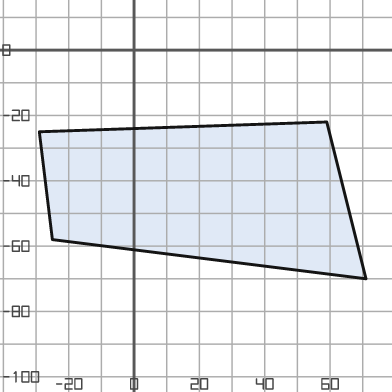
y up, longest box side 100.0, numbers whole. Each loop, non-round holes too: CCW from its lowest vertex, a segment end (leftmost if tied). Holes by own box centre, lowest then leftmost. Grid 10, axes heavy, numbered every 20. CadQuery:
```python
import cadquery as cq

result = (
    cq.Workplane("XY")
    .moveTo(71.0, -70.0)
    .lineTo(59.0, -22.0)
    .lineTo(-29.0, -25.0)
    .lineTo(-25.0, -58.0)
    .close()
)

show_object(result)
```